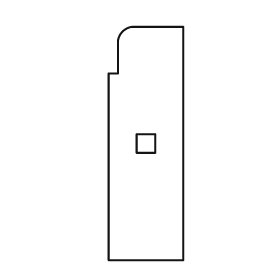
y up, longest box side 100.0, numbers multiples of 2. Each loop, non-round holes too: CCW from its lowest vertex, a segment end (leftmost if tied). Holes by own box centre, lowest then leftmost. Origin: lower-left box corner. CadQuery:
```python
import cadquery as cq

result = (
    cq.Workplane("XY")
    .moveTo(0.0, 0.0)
    .lineTo(32.0, 0.0)
    .lineTo(32.0, 100.0)
    .lineTo(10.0, 100.0)
    .threePointArc((6.0, 98.0), (4.0, 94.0))
    .lineTo(4.0, 80.0)
    .lineTo(0.0, 80.0)
    .close()
    .moveTo(12.0, 46.0)
    .lineTo(20.0, 46.0)
    .lineTo(20.0, 54.0)
    .lineTo(12.0, 54.0)
    .close()
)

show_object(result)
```